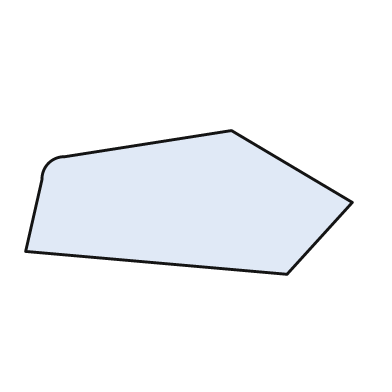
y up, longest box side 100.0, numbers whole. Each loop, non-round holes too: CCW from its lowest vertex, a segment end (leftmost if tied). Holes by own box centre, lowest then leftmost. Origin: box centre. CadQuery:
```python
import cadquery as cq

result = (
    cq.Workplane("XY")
    .moveTo(30.0, -22.0)
    .lineTo(50.0, 0.0)
    .lineTo(13.0, 22.0)
    .lineTo(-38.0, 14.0)
    .threePointArc((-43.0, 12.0), (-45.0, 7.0))
    .lineTo(-50.0, -15.0)
    .close()
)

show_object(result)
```